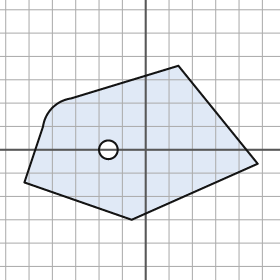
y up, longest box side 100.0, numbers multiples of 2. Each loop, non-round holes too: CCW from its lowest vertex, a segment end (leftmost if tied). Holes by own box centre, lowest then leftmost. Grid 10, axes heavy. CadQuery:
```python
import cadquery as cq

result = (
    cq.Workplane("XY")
    .moveTo(-6.0, -30.0)
    .lineTo(48.0, -6.0)
    .lineTo(14.0, 36.0)
    .lineTo(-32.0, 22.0)
    .threePointArc((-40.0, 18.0), (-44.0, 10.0))
    .lineTo(-52.0, -14.0)
    .close()
    .moveTo(-16.0, 0.0)
    .circle(4.0)
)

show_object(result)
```